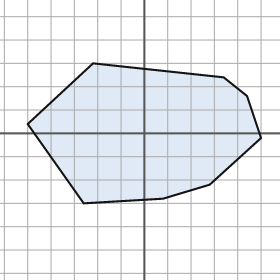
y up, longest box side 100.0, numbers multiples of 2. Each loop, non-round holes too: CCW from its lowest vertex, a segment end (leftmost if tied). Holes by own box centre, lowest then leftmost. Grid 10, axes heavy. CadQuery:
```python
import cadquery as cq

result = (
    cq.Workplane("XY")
    .moveTo(-26.0, -30.0)
    .lineTo(8.0, -28.0)
    .lineTo(28.0, -22.0)
    .lineTo(50.0, -2.0)
    .lineTo(44.0, 16.0)
    .lineTo(34.0, 24.0)
    .lineTo(-22.0, 30.0)
    .lineTo(-50.0, 4.0)
    .close()
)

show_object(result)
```